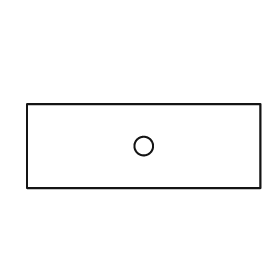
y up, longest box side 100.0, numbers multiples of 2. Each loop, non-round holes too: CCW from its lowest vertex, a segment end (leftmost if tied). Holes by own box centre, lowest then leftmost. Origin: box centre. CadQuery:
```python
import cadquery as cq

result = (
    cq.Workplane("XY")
    .moveTo(-50.0, -18.0)
    .lineTo(50.0, -18.0)
    .lineTo(50.0, 18.0)
    .lineTo(-50.0, 18.0)
    .close()
    .moveTo(0.0, 0.0)
    .circle(4.0)
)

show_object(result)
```